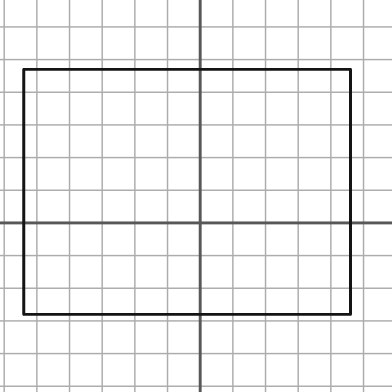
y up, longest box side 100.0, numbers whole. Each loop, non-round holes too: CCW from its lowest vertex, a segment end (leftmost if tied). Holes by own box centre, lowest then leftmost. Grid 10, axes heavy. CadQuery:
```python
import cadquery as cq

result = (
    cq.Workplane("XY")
    .moveTo(-54.0, -28.0)
    .lineTo(46.0, -28.0)
    .lineTo(46.0, 47.0)
    .lineTo(-54.0, 47.0)
    .close()
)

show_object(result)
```